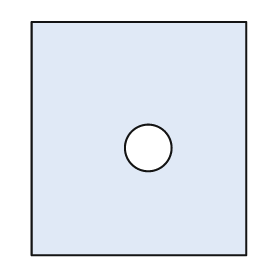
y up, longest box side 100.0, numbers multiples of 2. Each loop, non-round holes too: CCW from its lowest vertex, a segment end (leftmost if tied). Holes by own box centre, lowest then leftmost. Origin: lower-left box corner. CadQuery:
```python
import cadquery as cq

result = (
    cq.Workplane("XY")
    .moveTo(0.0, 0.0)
    .lineTo(92.0, 0.0)
    .lineTo(92.0, 100.0)
    .lineTo(0.0, 100.0)
    .close()
    .moveTo(50.0, 46.0)
    .circle(10.0)
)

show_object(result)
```